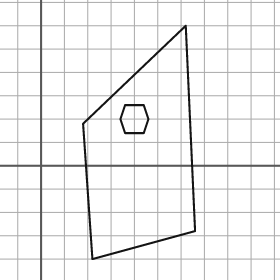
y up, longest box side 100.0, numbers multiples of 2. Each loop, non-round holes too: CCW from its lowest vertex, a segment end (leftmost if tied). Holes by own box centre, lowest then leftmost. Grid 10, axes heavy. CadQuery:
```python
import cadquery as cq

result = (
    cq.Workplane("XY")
    .moveTo(22.0, -40.0)
    .lineTo(66.0, -28.0)
    .lineTo(62.0, 60.0)
    .lineTo(18.0, 18.0)
    .close()
    .moveTo(36.0, 14.0)
    .lineTo(44.0, 14.0)
    .lineTo(46.0, 20.0)
    .lineTo(44.0, 26.0)
    .lineTo(36.0, 26.0)
    .lineTo(34.0, 20.0)
    .close()
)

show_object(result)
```